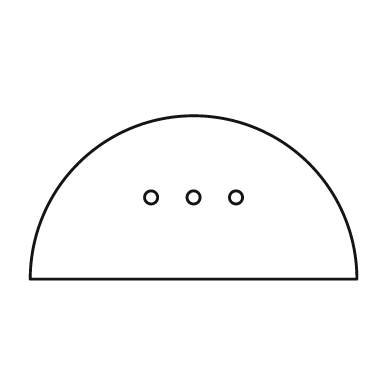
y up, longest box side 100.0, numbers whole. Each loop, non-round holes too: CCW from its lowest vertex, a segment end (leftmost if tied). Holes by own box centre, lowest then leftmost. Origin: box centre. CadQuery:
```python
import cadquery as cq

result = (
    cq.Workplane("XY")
    .moveTo(-50.0, -25.0)
    .lineTo(50.0, -25.0)
    .threePointArc((0.0, 25.0), (-50.0, -25.0))
    .close()
    .moveTo(-13.0, 0.0)
    .circle(2.0)
    .moveTo(0.0, 0.0)
    .circle(2.0)
    .moveTo(13.0, 0.0)
    .circle(2.0)
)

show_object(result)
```